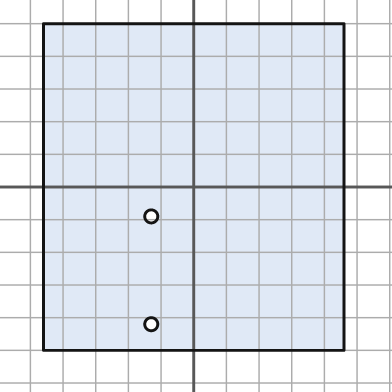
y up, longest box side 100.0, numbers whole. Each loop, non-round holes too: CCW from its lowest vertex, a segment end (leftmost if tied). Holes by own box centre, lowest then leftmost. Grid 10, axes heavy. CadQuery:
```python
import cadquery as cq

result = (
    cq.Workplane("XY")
    .moveTo(-46.0, -50.0)
    .lineTo(46.0, -50.0)
    .lineTo(46.0, 50.0)
    .lineTo(-46.0, 50.0)
    .close()
    .moveTo(-13.0, -42.0)
    .circle(2.0)
    .moveTo(-13.0, -9.0)
    .circle(2.0)
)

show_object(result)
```